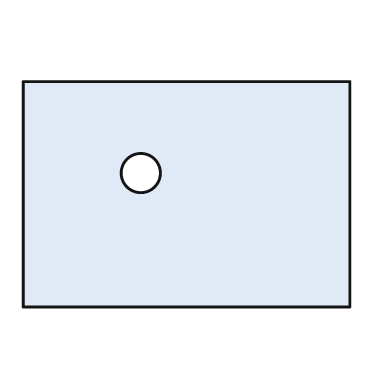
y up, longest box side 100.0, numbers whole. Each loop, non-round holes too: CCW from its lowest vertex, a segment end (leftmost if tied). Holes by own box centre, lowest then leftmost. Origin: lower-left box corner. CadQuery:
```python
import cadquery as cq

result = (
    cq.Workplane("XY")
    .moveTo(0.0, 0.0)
    .lineTo(100.0, 0.0)
    .lineTo(100.0, 69.0)
    .lineTo(0.0, 69.0)
    .close()
    .moveTo(36.0, 41.0)
    .circle(6.0)
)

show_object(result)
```